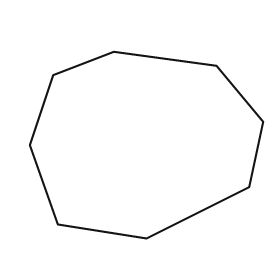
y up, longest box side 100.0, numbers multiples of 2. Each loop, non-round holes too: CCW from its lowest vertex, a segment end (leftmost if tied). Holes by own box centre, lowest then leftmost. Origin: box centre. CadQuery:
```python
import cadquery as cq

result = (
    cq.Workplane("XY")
    .moveTo(0.0, -40.0)
    .lineTo(44.0, -18.0)
    .lineTo(50.0, 10.0)
    .lineTo(30.0, 34.0)
    .lineTo(-14.0, 40.0)
    .lineTo(-40.0, 30.0)
    .lineTo(-50.0, 0.0)
    .lineTo(-38.0, -34.0)
    .close()
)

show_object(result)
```